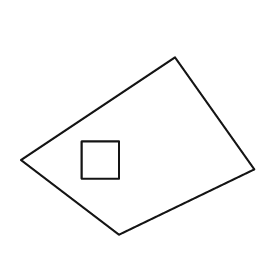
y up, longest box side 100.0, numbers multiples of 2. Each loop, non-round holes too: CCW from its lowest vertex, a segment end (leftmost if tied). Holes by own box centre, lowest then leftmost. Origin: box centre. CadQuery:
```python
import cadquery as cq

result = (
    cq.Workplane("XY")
    .moveTo(-8.0, -38.0)
    .lineTo(50.0, -10.0)
    .lineTo(16.0, 38.0)
    .lineTo(-50.0, -6.0)
    .close()
    .moveTo(-24.0, -14.0)
    .lineTo(-8.0, -14.0)
    .lineTo(-8.0, 2.0)
    .lineTo(-24.0, 2.0)
    .close()
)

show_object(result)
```